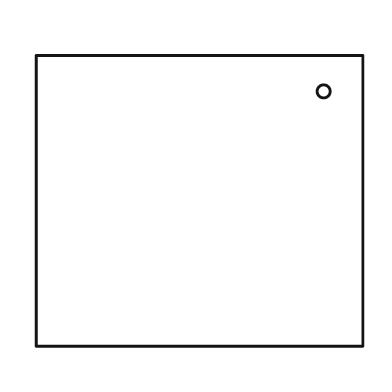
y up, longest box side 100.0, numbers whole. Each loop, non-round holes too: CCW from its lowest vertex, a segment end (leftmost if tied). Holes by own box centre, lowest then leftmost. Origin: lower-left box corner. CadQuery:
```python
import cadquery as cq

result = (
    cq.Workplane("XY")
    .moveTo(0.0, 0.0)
    .lineTo(100.0, 0.0)
    .lineTo(100.0, 89.0)
    .lineTo(0.0, 89.0)
    .close()
    .moveTo(88.0, 78.0)
    .circle(2.0)
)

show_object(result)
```